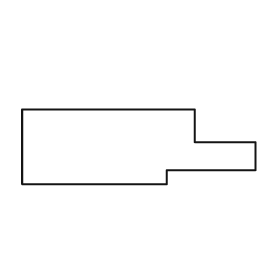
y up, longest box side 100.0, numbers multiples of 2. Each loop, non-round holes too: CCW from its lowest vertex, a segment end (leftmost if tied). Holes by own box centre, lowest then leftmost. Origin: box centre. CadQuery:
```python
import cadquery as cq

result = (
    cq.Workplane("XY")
    .moveTo(-50.0, -16.0)
    .lineTo(12.0, -16.0)
    .lineTo(12.0, -10.0)
    .lineTo(50.0, -10.0)
    .lineTo(50.0, 2.0)
    .lineTo(24.0, 2.0)
    .lineTo(24.0, 16.0)
    .lineTo(-50.0, 16.0)
    .close()
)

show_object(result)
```